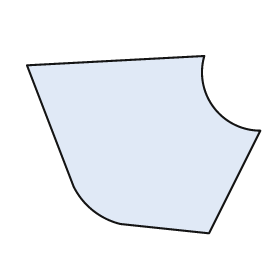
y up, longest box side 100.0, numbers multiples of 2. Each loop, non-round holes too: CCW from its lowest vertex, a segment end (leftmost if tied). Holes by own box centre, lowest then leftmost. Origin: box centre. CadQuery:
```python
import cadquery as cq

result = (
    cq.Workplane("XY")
    .moveTo(28.0, -38.0)
    .lineTo(50.0, 6.0)
    .threePointArc((30.0, 16.0), (26.0, 38.0))
    .lineTo(-50.0, 34.0)
    .lineTo(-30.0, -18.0)
    .threePointArc((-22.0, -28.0), (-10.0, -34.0))
    .close()
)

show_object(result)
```